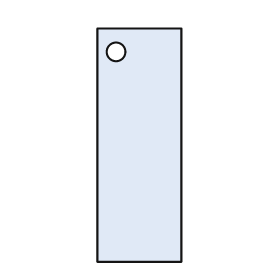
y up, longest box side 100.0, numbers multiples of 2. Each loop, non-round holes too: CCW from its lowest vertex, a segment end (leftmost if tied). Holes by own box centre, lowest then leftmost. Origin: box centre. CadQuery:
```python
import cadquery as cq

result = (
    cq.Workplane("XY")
    .moveTo(-18.0, -50.0)
    .lineTo(18.0, -50.0)
    .lineTo(18.0, 50.0)
    .lineTo(-18.0, 50.0)
    .close()
    .moveTo(-10.0, 40.0)
    .circle(4.0)
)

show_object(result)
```